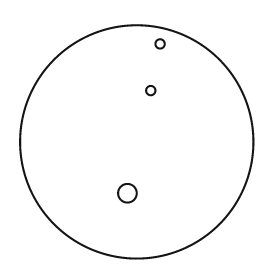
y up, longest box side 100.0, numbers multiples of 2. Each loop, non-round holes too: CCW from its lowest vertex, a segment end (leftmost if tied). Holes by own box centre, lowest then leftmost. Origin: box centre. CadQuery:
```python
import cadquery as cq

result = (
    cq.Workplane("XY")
    .moveTo(0.0, 0.0)
    .circle(50.0)
    .moveTo(-4.0, -22.0)
    .circle(4.0)
    .moveTo(6.0, 22.0)
    .circle(2.0)
    .moveTo(10.0, 42.0)
    .circle(2.0)
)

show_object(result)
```